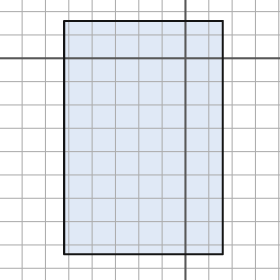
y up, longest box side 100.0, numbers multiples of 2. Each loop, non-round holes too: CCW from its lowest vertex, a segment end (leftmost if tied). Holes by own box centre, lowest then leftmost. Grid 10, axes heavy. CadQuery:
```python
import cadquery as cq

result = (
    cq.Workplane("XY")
    .moveTo(-52.0, -84.0)
    .lineTo(16.0, -84.0)
    .lineTo(16.0, 16.0)
    .lineTo(-52.0, 16.0)
    .close()
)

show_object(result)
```